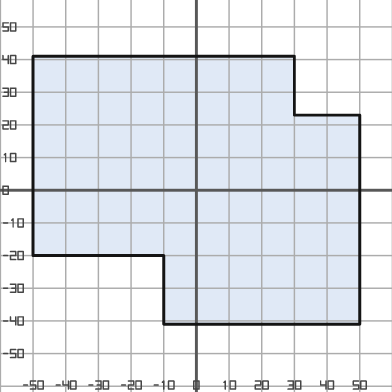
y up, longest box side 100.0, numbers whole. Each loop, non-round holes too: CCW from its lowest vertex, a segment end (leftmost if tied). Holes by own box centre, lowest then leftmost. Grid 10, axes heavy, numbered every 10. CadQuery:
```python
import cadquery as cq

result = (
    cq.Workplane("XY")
    .moveTo(-10.0, -41.0)
    .lineTo(50.0, -41.0)
    .lineTo(50.0, 23.0)
    .lineTo(30.0, 23.0)
    .lineTo(30.0, 41.0)
    .lineTo(-50.0, 41.0)
    .lineTo(-50.0, -20.0)
    .lineTo(-10.0, -20.0)
    .close()
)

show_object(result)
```